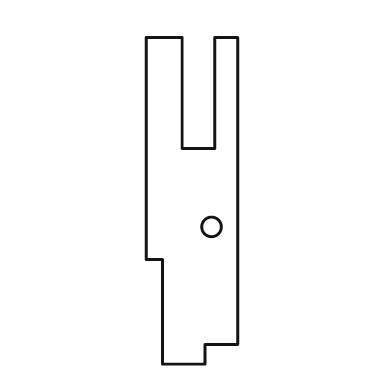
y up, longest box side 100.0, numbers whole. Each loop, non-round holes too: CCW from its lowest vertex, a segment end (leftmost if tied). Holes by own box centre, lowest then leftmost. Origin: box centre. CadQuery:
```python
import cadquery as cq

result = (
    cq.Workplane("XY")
    .moveTo(-9.0, -50.0)
    .lineTo(4.0, -50.0)
    .lineTo(4.0, -44.0)
    .lineTo(14.0, -44.0)
    .lineTo(14.0, 50.0)
    .lineTo(7.0, 50.0)
    .lineTo(7.0, 16.0)
    .lineTo(-3.0, 16.0)
    .lineTo(-3.0, 50.0)
    .lineTo(-14.0, 50.0)
    .lineTo(-14.0, -18.0)
    .lineTo(-9.0, -18.0)
    .close()
    .moveTo(6.0, -8.0)
    .circle(3.0)
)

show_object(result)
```